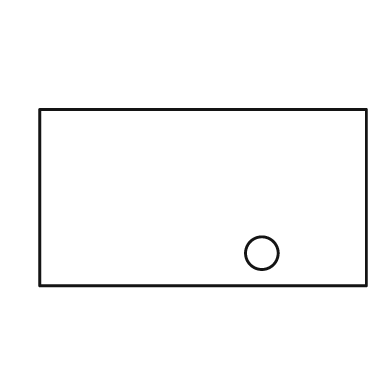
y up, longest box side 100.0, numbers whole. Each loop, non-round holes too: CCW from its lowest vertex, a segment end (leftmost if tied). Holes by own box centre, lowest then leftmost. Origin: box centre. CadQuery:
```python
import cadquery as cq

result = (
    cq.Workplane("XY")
    .moveTo(-50.0, -27.0)
    .lineTo(50.0, -27.0)
    .lineTo(50.0, 27.0)
    .lineTo(-50.0, 27.0)
    .close()
    .moveTo(18.0, -17.0)
    .circle(5.0)
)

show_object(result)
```